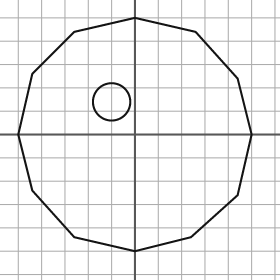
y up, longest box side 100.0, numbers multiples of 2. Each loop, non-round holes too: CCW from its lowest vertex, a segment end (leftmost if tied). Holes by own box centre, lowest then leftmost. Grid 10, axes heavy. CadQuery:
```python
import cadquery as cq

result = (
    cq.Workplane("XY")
    .moveTo(0.0, -50.0)
    .lineTo(24.0, -44.0)
    .lineTo(44.0, -26.0)
    .lineTo(50.0, 0.0)
    .lineTo(44.0, 24.0)
    .lineTo(26.0, 44.0)
    .lineTo(0.0, 50.0)
    .lineTo(-26.0, 44.0)
    .lineTo(-44.0, 26.0)
    .lineTo(-50.0, 0.0)
    .lineTo(-44.0, -24.0)
    .lineTo(-26.0, -44.0)
    .close()
    .moveTo(-10.0, 14.0)
    .circle(8.0)
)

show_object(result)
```